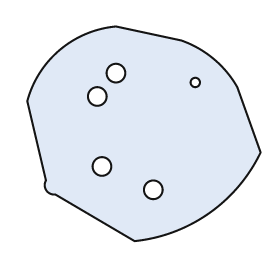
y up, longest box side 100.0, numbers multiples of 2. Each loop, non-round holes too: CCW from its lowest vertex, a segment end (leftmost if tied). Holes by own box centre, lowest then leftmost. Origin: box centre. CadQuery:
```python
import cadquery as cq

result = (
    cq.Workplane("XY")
    .moveTo(-4.0, -46.0)
    .threePointArc((28.0, -34.0), (50.0, -8.0))
    .lineTo(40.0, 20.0)
    .threePointArc((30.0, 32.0), (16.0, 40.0))
    .lineTo(-12.0, 46.0)
    .threePointArc((-36.0, 36.0), (-50.0, 14.0))
    .lineTo(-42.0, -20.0)
    .threePointArc((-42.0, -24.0), (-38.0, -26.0))
    .close()
    .moveTo(4.0, -24.0)
    .circle(4.0)
    .moveTo(-18.0, -14.0)
    .circle(4.0)
    .moveTo(-20.0, 16.0)
    .circle(4.0)
    .moveTo(22.0, 22.0)
    .circle(2.0)
    .moveTo(-12.0, 26.0)
    .circle(4.0)
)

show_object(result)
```